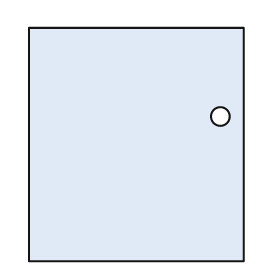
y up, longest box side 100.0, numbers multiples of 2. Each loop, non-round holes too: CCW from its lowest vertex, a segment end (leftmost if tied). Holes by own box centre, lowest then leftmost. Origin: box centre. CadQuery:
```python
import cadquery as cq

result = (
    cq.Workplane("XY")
    .moveTo(-46.0, -50.0)
    .lineTo(46.0, -50.0)
    .lineTo(46.0, 50.0)
    .lineTo(-46.0, 50.0)
    .close()
    .moveTo(36.0, 12.0)
    .circle(4.0)
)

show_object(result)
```